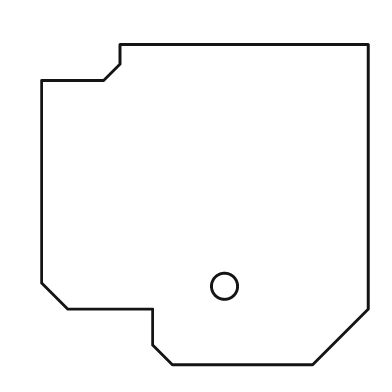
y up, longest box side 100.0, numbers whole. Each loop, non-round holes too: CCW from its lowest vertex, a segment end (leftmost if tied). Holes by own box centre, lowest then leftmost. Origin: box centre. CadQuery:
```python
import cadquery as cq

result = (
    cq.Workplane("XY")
    .moveTo(-10.0, -49.0)
    .lineTo(33.0, -49.0)
    .lineTo(50.0, -32.0)
    .lineTo(50.0, 49.0)
    .lineTo(-26.0, 49.0)
    .lineTo(-26.0, 43.0)
    .lineTo(-31.0, 38.0)
    .lineTo(-50.0, 38.0)
    .lineTo(-50.0, -24.0)
    .lineTo(-42.0, -32.0)
    .lineTo(-16.0, -32.0)
    .lineTo(-16.0, -43.0)
    .close()
    .moveTo(6.0, -25.0)
    .circle(4.0)
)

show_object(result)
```